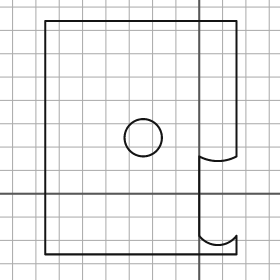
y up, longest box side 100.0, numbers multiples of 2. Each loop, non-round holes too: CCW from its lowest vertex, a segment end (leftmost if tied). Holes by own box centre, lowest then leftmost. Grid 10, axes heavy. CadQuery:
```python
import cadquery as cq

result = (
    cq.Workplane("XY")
    .moveTo(-66.0, -26.0)
    .lineTo(16.0, -26.0)
    .lineTo(16.0, -18.0)
    .threePointArc((8.0, -22.0), (0.0, -18.0))
    .lineTo(0.0, 16.0)
    .threePointArc((8.0, 14.0), (16.0, 16.0))
    .lineTo(16.0, 74.0)
    .lineTo(-66.0, 74.0)
    .close()
    .moveTo(-24.0, 24.0)
    .circle(8.0)
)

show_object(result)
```